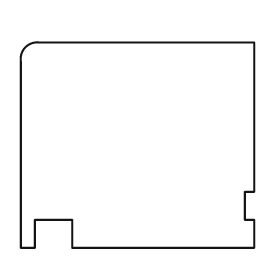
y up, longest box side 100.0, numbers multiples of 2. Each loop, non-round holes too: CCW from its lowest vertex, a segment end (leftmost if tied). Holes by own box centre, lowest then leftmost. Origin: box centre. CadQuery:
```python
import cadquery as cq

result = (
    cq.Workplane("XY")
    .moveTo(-50.0, -44.0)
    .lineTo(-44.0, -44.0)
    .lineTo(-44.0, -32.0)
    .lineTo(-28.0, -32.0)
    .lineTo(-28.0, -44.0)
    .lineTo(50.0, -44.0)
    .lineTo(50.0, -32.0)
    .lineTo(46.0, -32.0)
    .lineTo(46.0, -20.0)
    .lineTo(50.0, -20.0)
    .lineTo(50.0, 44.0)
    .lineTo(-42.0, 44.0)
    .threePointArc((-48.0, 42.0), (-50.0, 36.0))
    .close()
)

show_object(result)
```